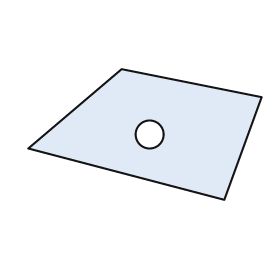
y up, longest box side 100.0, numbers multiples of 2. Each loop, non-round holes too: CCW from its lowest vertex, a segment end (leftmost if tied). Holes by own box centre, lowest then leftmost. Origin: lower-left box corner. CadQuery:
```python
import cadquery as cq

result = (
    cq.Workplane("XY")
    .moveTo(84.0, 0.0)
    .lineTo(100.0, 44.0)
    .lineTo(40.0, 56.0)
    .lineTo(0.0, 22.0)
    .close()
    .moveTo(52.0, 28.0)
    .circle(6.0)
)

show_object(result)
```